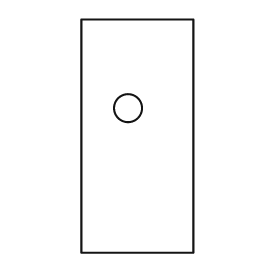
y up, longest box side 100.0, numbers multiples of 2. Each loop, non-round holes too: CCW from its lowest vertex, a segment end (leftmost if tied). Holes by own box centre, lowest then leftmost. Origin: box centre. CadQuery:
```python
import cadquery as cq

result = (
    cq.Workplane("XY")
    .moveTo(-24.0, -50.0)
    .lineTo(24.0, -50.0)
    .lineTo(24.0, 50.0)
    .lineTo(-24.0, 50.0)
    .close()
    .moveTo(-4.0, 12.0)
    .circle(6.0)
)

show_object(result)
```